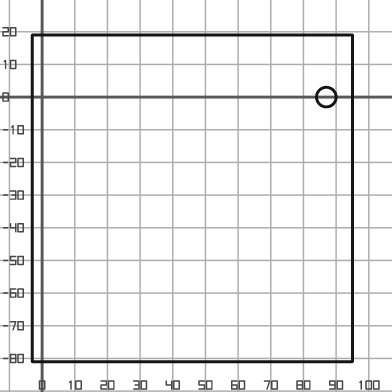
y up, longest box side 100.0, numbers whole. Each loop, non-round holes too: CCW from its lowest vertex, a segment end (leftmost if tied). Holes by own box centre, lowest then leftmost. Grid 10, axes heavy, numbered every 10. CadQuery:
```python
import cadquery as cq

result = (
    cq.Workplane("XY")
    .moveTo(-3.0, -81.0)
    .lineTo(95.0, -81.0)
    .lineTo(95.0, 19.0)
    .lineTo(-3.0, 19.0)
    .close()
    .moveTo(87.0, 0.0)
    .circle(3.0)
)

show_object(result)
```